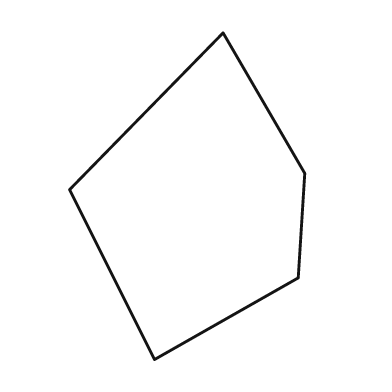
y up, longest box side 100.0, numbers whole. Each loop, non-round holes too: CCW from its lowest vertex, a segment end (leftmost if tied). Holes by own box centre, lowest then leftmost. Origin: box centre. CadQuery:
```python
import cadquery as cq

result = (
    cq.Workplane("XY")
    .moveTo(-10.0, -50.0)
    .lineTo(34.0, -25.0)
    .lineTo(36.0, 7.0)
    .lineTo(11.0, 50.0)
    .lineTo(-36.0, 2.0)
    .close()
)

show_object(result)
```